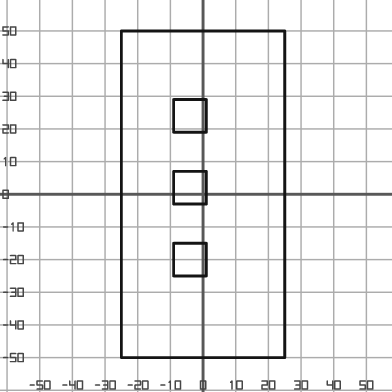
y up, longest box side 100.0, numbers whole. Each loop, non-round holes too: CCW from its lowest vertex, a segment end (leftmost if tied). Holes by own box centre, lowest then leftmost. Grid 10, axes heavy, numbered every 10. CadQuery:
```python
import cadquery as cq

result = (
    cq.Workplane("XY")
    .moveTo(-25.0, -50.0)
    .lineTo(25.0, -50.0)
    .lineTo(25.0, 50.0)
    .lineTo(-25.0, 50.0)
    .close()
    .moveTo(-9.0, -25.0)
    .lineTo(1.0, -25.0)
    .lineTo(1.0, -15.0)
    .lineTo(-9.0, -15.0)
    .close()
    .moveTo(-9.0, -3.0)
    .lineTo(1.0, -3.0)
    .lineTo(1.0, 7.0)
    .lineTo(-9.0, 7.0)
    .close()
    .moveTo(-9.0, 19.0)
    .lineTo(1.0, 19.0)
    .lineTo(1.0, 29.0)
    .lineTo(-9.0, 29.0)
    .close()
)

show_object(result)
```